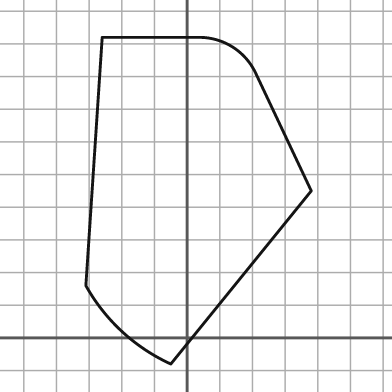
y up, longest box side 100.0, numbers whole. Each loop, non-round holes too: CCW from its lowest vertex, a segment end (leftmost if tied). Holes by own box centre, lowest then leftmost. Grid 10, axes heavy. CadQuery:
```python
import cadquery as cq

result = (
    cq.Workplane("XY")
    .moveTo(-5.0, -8.0)
    .lineTo(38.0, 45.0)
    .lineTo(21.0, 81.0)
    .threePointArc((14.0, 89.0), (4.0, 92.0))
    .lineTo(-26.0, 92.0)
    .lineTo(-31.0, 16.0)
    .threePointArc((-20.0, 2.0), (-5.0, -8.0))
    .close()
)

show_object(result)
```